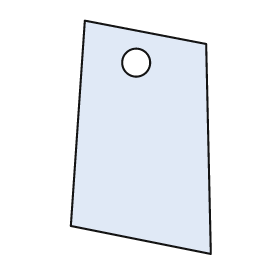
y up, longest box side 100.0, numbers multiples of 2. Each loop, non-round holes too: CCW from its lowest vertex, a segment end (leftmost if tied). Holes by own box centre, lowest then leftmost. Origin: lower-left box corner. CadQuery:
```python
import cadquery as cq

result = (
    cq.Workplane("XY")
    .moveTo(60.0, 0.0)
    .lineTo(58.0, 90.0)
    .lineTo(6.0, 100.0)
    .lineTo(0.0, 12.0)
    .close()
    .moveTo(28.0, 82.0)
    .circle(6.0)
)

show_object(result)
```